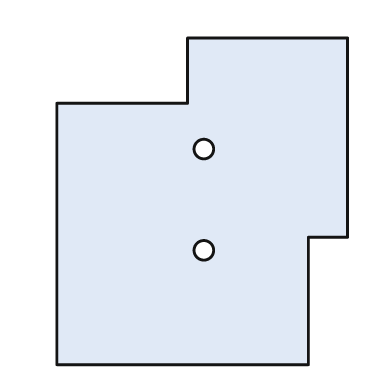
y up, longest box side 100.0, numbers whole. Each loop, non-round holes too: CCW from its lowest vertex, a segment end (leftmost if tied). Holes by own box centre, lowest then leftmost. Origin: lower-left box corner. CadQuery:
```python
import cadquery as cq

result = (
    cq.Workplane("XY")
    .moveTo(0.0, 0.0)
    .lineTo(77.0, 0.0)
    .lineTo(77.0, 39.0)
    .lineTo(89.0, 39.0)
    .lineTo(89.0, 100.0)
    .lineTo(40.0, 100.0)
    .lineTo(40.0, 80.0)
    .lineTo(0.0, 80.0)
    .close()
    .moveTo(45.0, 35.0)
    .circle(3.0)
    .moveTo(45.0, 66.0)
    .circle(3.0)
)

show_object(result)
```